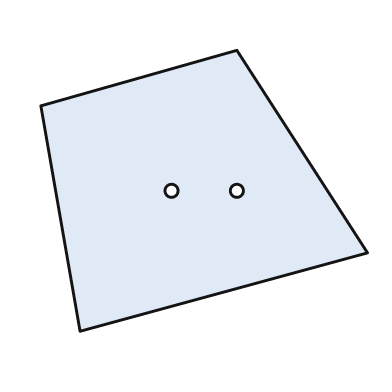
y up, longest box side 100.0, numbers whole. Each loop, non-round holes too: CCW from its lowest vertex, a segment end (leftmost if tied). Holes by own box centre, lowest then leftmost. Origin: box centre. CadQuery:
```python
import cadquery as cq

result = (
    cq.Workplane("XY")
    .moveTo(-38.0, -43.0)
    .lineTo(50.0, -19.0)
    .lineTo(10.0, 43.0)
    .lineTo(-50.0, 26.0)
    .close()
    .moveTo(-10.0, 0.0)
    .circle(2.0)
    .moveTo(10.0, 0.0)
    .circle(2.0)
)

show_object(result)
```